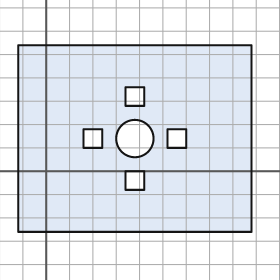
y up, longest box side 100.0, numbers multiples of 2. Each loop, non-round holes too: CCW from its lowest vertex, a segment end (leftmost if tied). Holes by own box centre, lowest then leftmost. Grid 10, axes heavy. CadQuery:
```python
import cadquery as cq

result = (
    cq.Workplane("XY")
    .moveTo(-12.0, -26.0)
    .lineTo(88.0, -26.0)
    .lineTo(88.0, 54.0)
    .lineTo(-12.0, 54.0)
    .close()
    .moveTo(34.0, -8.0)
    .lineTo(42.0, -8.0)
    .lineTo(42.0, 0.0)
    .lineTo(34.0, 0.0)
    .close()
    .moveTo(16.0, 10.0)
    .lineTo(24.0, 10.0)
    .lineTo(24.0, 18.0)
    .lineTo(16.0, 18.0)
    .close()
    .moveTo(38.0, 14.0)
    .circle(8.0)
    .moveTo(52.0, 10.0)
    .lineTo(60.0, 10.0)
    .lineTo(60.0, 18.0)
    .lineTo(52.0, 18.0)
    .close()
    .moveTo(34.0, 28.0)
    .lineTo(42.0, 28.0)
    .lineTo(42.0, 36.0)
    .lineTo(34.0, 36.0)
    .close()
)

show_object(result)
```